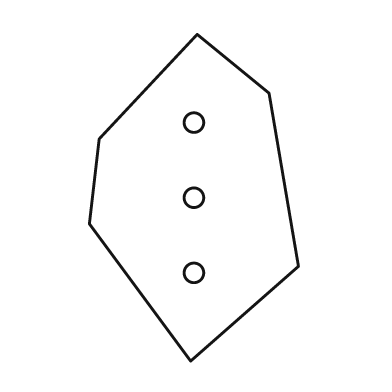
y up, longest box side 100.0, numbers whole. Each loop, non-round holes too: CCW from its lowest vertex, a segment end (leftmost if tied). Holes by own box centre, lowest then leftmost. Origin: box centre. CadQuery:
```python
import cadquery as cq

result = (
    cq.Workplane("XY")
    .moveTo(-1.0, -50.0)
    .lineTo(32.0, -21.0)
    .lineTo(23.0, 32.0)
    .lineTo(1.0, 50.0)
    .lineTo(-29.0, 18.0)
    .lineTo(-32.0, -8.0)
    .close()
    .moveTo(0.0, -23.0)
    .circle(3.0)
    .moveTo(0.0, 0.0)
    .circle(3.0)
    .moveTo(0.0, 23.0)
    .circle(3.0)
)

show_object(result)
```